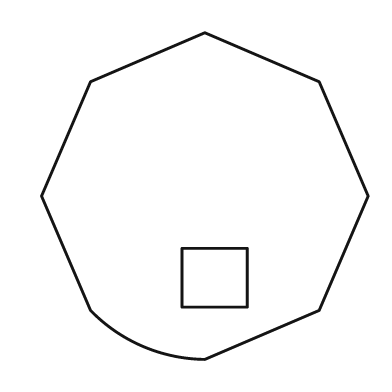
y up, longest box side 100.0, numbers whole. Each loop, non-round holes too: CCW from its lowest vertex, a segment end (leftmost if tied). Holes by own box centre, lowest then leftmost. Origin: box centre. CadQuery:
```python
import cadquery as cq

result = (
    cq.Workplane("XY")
    .moveTo(0.0, -50.0)
    .lineTo(35.0, -35.0)
    .lineTo(50.0, 0.0)
    .lineTo(35.0, 35.0)
    .lineTo(0.0, 50.0)
    .lineTo(-35.0, 35.0)
    .lineTo(-50.0, 0.0)
    .lineTo(-35.0, -35.0)
    .threePointArc((-19.0, -46.0), (0.0, -50.0))
    .close()
    .moveTo(-7.0, -34.0)
    .lineTo(13.0, -34.0)
    .lineTo(13.0, -16.0)
    .lineTo(-7.0, -16.0)
    .close()
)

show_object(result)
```